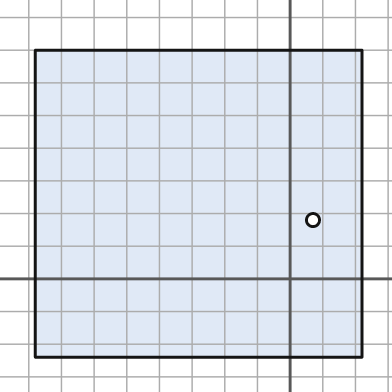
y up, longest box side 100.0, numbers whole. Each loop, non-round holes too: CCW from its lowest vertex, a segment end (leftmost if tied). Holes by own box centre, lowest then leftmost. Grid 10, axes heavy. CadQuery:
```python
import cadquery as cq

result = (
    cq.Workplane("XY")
    .moveTo(-78.0, -24.0)
    .lineTo(22.0, -24.0)
    .lineTo(22.0, 70.0)
    .lineTo(-78.0, 70.0)
    .close()
    .moveTo(7.0, 18.0)
    .circle(2.0)
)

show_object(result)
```